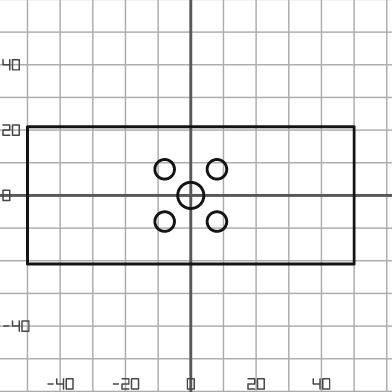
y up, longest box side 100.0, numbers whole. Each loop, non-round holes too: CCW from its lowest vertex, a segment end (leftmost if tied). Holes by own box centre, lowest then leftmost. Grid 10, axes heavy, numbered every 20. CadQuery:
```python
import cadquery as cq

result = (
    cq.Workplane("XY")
    .moveTo(-50.0, -21.0)
    .lineTo(50.0, -21.0)
    .lineTo(50.0, 21.0)
    .lineTo(-50.0, 21.0)
    .close()
    .moveTo(-8.0, -8.0)
    .circle(3.0)
    .moveTo(8.0, -8.0)
    .circle(3.0)
    .moveTo(0.0, 0.0)
    .circle(4.0)
    .moveTo(-8.0, 8.0)
    .circle(3.0)
    .moveTo(8.0, 8.0)
    .circle(3.0)
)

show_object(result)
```